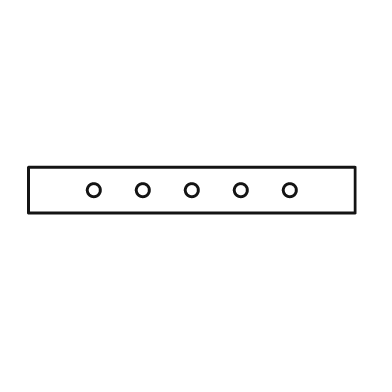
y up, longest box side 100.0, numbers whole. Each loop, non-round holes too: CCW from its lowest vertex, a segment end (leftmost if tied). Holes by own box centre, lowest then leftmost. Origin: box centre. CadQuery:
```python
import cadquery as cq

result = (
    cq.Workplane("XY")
    .moveTo(-50.0, -7.0)
    .lineTo(50.0, -7.0)
    .lineTo(50.0, 7.0)
    .lineTo(-50.0, 7.0)
    .close()
    .moveTo(-30.0, 0.0)
    .circle(2.0)
    .moveTo(-15.0, 0.0)
    .circle(2.0)
    .moveTo(0.0, 0.0)
    .circle(2.0)
    .moveTo(15.0, 0.0)
    .circle(2.0)
    .moveTo(30.0, 0.0)
    .circle(2.0)
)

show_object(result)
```